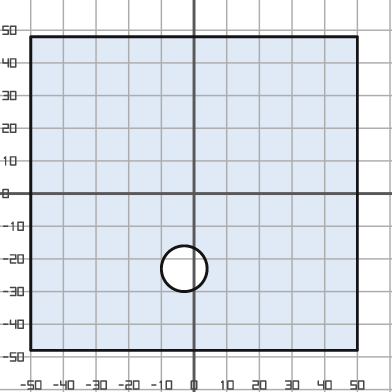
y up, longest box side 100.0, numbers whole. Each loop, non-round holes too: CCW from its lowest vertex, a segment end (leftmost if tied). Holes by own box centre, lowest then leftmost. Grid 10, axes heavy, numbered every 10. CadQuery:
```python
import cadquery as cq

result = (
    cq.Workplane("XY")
    .moveTo(-50.0, -48.0)
    .lineTo(50.0, -48.0)
    .lineTo(50.0, 48.0)
    .lineTo(-50.0, 48.0)
    .close()
    .moveTo(-3.0, -23.0)
    .circle(7.0)
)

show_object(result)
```